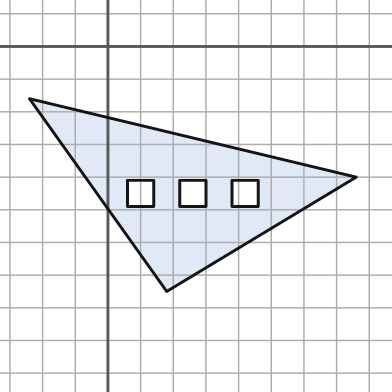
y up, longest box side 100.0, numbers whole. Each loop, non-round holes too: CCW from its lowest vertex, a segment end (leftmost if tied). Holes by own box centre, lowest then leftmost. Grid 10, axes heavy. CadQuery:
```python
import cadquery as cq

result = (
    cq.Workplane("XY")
    .moveTo(18.0, -75.0)
    .lineTo(76.0, -40.0)
    .lineTo(-24.0, -16.0)
    .close()
    .moveTo(6.0, -49.0)
    .lineTo(14.0, -49.0)
    .lineTo(14.0, -41.0)
    .lineTo(6.0, -41.0)
    .close()
    .moveTo(22.0, -49.0)
    .lineTo(30.0, -49.0)
    .lineTo(30.0, -41.0)
    .lineTo(22.0, -41.0)
    .close()
    .moveTo(38.0, -49.0)
    .lineTo(46.0, -49.0)
    .lineTo(46.0, -41.0)
    .lineTo(38.0, -41.0)
    .close()
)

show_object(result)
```